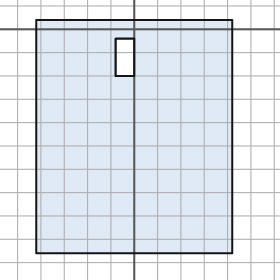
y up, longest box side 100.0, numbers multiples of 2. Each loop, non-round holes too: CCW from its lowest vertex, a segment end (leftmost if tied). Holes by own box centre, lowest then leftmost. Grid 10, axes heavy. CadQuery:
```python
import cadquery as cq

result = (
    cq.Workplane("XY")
    .moveTo(-42.0, -96.0)
    .lineTo(42.0, -96.0)
    .lineTo(42.0, 4.0)
    .lineTo(-42.0, 4.0)
    .close()
    .moveTo(-8.0, -20.0)
    .lineTo(0.0, -20.0)
    .lineTo(0.0, -4.0)
    .lineTo(-8.0, -4.0)
    .close()
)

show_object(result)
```